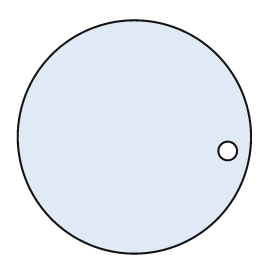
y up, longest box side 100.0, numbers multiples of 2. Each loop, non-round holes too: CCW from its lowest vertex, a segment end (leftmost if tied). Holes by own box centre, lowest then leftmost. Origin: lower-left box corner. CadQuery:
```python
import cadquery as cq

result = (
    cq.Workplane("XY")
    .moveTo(50.0, 50.0)
    .circle(50.0)
    .moveTo(90.0, 44.0)
    .circle(4.0)
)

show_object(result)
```